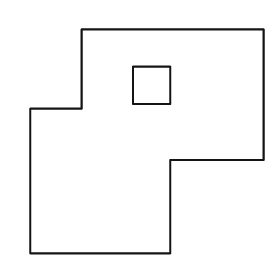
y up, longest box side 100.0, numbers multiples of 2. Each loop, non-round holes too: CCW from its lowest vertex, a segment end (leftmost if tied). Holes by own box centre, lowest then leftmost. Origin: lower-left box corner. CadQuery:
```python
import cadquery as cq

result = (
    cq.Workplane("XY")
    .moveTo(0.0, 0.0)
    .lineTo(60.0, 0.0)
    .lineTo(60.0, 40.0)
    .lineTo(100.0, 40.0)
    .lineTo(100.0, 96.0)
    .lineTo(22.0, 96.0)
    .lineTo(22.0, 62.0)
    .lineTo(0.0, 62.0)
    .close()
    .moveTo(44.0, 64.0)
    .lineTo(60.0, 64.0)
    .lineTo(60.0, 80.0)
    .lineTo(44.0, 80.0)
    .close()
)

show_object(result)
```